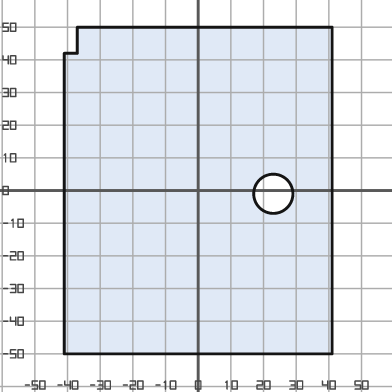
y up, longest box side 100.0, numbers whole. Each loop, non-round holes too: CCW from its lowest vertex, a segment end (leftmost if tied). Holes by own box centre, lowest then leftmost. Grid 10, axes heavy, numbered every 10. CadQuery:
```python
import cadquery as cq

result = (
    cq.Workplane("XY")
    .moveTo(-41.0, -50.0)
    .lineTo(41.0, -50.0)
    .lineTo(41.0, 50.0)
    .lineTo(-37.0, 50.0)
    .lineTo(-37.0, 42.0)
    .lineTo(-41.0, 42.0)
    .close()
    .moveTo(23.0, -1.0)
    .circle(6.0)
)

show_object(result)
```